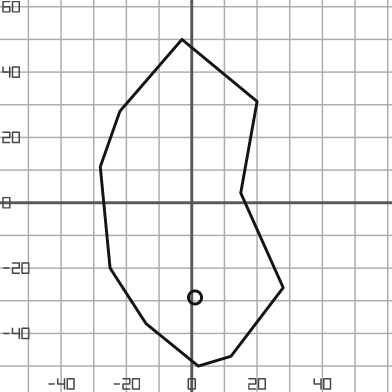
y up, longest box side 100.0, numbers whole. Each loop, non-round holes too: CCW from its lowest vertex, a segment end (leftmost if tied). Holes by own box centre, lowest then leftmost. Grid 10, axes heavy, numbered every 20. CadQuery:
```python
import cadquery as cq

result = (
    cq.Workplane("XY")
    .moveTo(2.0, -50.0)
    .lineTo(12.0, -47.0)
    .lineTo(28.0, -26.0)
    .lineTo(15.0, 3.0)
    .lineTo(20.0, 31.0)
    .lineTo(-3.0, 50.0)
    .lineTo(-22.0, 28.0)
    .lineTo(-28.0, 11.0)
    .lineTo(-25.0, -20.0)
    .lineTo(-14.0, -37.0)
    .close()
    .moveTo(1.0, -29.0)
    .circle(2.0)
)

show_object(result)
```